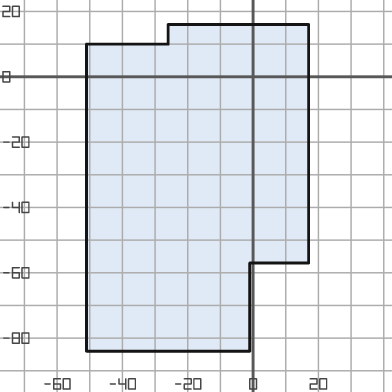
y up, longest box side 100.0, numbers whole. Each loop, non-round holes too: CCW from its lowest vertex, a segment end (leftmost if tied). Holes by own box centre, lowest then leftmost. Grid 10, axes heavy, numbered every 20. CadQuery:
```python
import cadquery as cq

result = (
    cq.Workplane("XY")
    .moveTo(-51.0, -84.0)
    .lineTo(-1.0, -84.0)
    .lineTo(-1.0, -57.0)
    .lineTo(17.0, -57.0)
    .lineTo(17.0, 16.0)
    .lineTo(-26.0, 16.0)
    .lineTo(-26.0, 10.0)
    .lineTo(-51.0, 10.0)
    .close()
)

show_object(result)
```